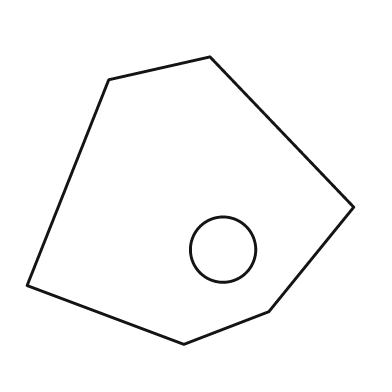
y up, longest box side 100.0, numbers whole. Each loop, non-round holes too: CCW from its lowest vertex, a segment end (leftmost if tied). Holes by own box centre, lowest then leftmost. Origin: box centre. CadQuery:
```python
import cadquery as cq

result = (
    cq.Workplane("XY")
    .moveTo(-2.0, -44.0)
    .lineTo(24.0, -34.0)
    .lineTo(50.0, -2.0)
    .lineTo(6.0, 44.0)
    .lineTo(-25.0, 37.0)
    .lineTo(-50.0, -26.0)
    .close()
    .moveTo(10.0, -15.0)
    .circle(10.0)
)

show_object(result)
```